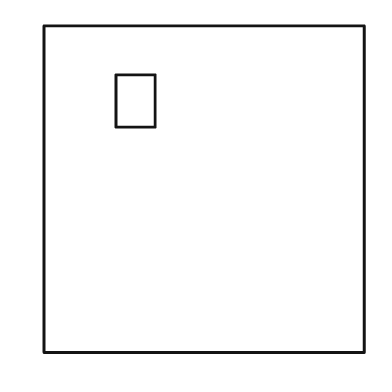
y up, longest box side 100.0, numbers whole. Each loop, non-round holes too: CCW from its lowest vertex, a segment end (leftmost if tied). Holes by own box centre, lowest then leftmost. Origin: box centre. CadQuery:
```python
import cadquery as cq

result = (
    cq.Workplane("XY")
    .moveTo(-49.0, -50.0)
    .lineTo(49.0, -50.0)
    .lineTo(49.0, 50.0)
    .lineTo(-49.0, 50.0)
    .close()
    .moveTo(-27.0, 19.0)
    .lineTo(-15.0, 19.0)
    .lineTo(-15.0, 35.0)
    .lineTo(-27.0, 35.0)
    .close()
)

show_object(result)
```